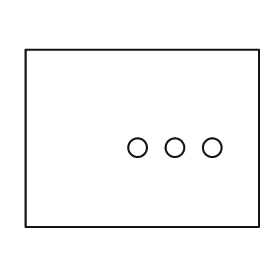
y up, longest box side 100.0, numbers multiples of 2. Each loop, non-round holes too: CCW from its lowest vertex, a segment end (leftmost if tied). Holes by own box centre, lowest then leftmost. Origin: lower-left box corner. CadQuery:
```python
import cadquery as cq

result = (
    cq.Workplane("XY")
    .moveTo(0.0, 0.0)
    .lineTo(100.0, 0.0)
    .lineTo(100.0, 76.0)
    .lineTo(0.0, 76.0)
    .close()
    .moveTo(48.0, 34.0)
    .circle(4.0)
    .moveTo(64.0, 34.0)
    .circle(4.0)
    .moveTo(80.0, 34.0)
    .circle(4.0)
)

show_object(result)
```